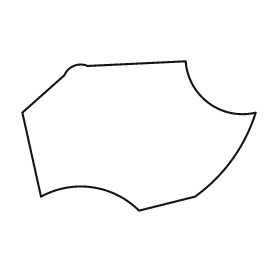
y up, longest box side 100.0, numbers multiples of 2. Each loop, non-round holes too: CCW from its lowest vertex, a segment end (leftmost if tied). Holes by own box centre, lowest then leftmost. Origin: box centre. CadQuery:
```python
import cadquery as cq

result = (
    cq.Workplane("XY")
    .moveTo(0.0, -32.0)
    .lineTo(24.0, -26.0)
    .threePointArc((40.0, -10.0), (50.0, 10.0))
    .threePointArc((30.0, 14.0), (20.0, 32.0))
    .lineTo(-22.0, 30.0)
    .threePointArc((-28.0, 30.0), (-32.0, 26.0))
    .lineTo(-50.0, 10.0)
    .lineTo(-42.0, -26.0)
    .threePointArc((-20.0, -22.0), (0.0, -32.0))
    .close()
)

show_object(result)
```